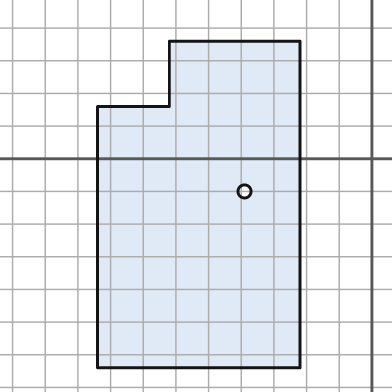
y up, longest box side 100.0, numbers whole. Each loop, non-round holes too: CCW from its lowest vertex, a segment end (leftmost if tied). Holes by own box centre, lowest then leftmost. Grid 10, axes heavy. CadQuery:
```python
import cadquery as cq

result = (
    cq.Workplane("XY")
    .moveTo(-84.0, -64.0)
    .lineTo(-22.0, -64.0)
    .lineTo(-22.0, 36.0)
    .lineTo(-62.0, 36.0)
    .lineTo(-62.0, 16.0)
    .lineTo(-84.0, 16.0)
    .close()
    .moveTo(-39.0, -10.0)
    .circle(2.0)
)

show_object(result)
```